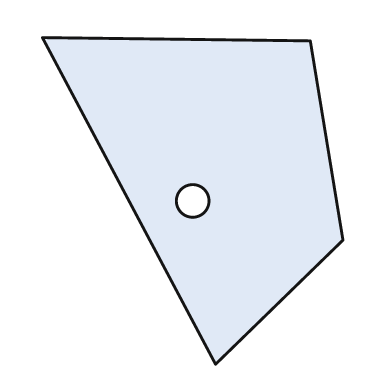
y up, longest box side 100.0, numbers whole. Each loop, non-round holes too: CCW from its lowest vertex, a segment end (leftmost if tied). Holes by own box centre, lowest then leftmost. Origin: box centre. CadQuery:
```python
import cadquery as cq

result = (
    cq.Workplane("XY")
    .moveTo(7.0, -50.0)
    .lineTo(46.0, -12.0)
    .lineTo(36.0, 49.0)
    .lineTo(-46.0, 50.0)
    .close()
    .moveTo(0.0, 0.0)
    .circle(5.0)
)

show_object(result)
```